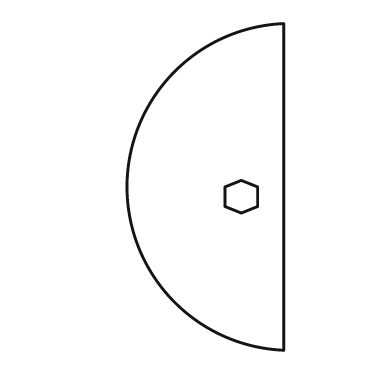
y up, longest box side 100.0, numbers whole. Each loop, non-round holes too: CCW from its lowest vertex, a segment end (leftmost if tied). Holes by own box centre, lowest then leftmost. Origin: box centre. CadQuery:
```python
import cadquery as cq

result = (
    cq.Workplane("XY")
    .moveTo(24.0, -50.0)
    .lineTo(24.0, 50.0)
    .threePointArc((-24.0, 0.0), (24.0, -50.0))
    .close()
    .moveTo(11.0, -8.0)
    .lineTo(16.0, -6.0)
    .lineTo(16.0, 0.0)
    .lineTo(11.0, 2.0)
    .lineTo(6.0, 0.0)
    .lineTo(6.0, -6.0)
    .close()
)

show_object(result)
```